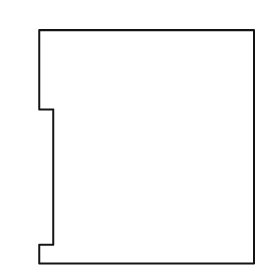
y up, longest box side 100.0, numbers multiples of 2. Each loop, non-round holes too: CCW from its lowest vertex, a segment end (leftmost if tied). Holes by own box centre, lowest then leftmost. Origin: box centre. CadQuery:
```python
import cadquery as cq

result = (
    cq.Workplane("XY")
    .moveTo(-46.0, -50.0)
    .lineTo(46.0, -50.0)
    .lineTo(46.0, 50.0)
    .lineTo(-46.0, 50.0)
    .lineTo(-46.0, 16.0)
    .lineTo(-40.0, 16.0)
    .lineTo(-40.0, -42.0)
    .lineTo(-46.0, -42.0)
    .close()
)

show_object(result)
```